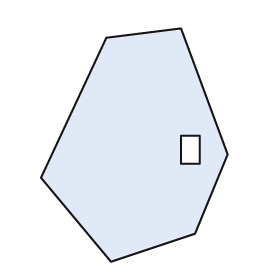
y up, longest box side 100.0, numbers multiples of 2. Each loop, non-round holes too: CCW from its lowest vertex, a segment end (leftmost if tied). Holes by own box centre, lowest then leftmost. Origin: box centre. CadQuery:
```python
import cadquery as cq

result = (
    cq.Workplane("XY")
    .moveTo(-10.0, -50.0)
    .lineTo(26.0, -38.0)
    .lineTo(40.0, -4.0)
    .lineTo(20.0, 50.0)
    .lineTo(-12.0, 46.0)
    .lineTo(-40.0, -14.0)
    .close()
    .moveTo(20.0, -8.0)
    .lineTo(28.0, -8.0)
    .lineTo(28.0, 4.0)
    .lineTo(20.0, 4.0)
    .close()
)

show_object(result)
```